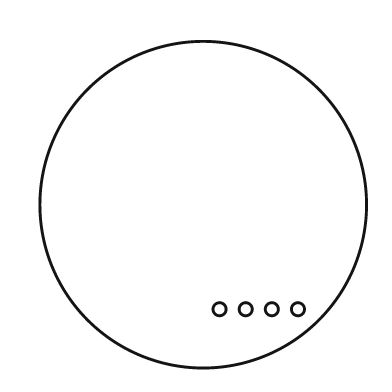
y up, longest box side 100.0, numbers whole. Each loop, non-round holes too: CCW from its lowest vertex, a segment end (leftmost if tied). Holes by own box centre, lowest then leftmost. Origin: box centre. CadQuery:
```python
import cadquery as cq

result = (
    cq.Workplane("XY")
    .moveTo(0.0, 0.0)
    .circle(50.0)
    .moveTo(5.0, -32.0)
    .circle(2.0)
    .moveTo(13.0, -32.0)
    .circle(2.0)
    .moveTo(21.0, -32.0)
    .circle(2.0)
    .moveTo(29.0, -32.0)
    .circle(2.0)
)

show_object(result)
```